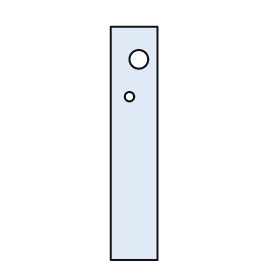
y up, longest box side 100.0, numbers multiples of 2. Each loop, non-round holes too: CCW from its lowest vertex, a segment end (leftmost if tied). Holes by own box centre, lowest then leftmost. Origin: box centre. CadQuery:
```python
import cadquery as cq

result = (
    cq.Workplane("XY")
    .moveTo(-10.0, -50.0)
    .lineTo(10.0, -50.0)
    .lineTo(10.0, 50.0)
    .lineTo(-10.0, 50.0)
    .close()
    .moveTo(-2.0, 20.0)
    .circle(2.0)
    .moveTo(2.0, 36.0)
    .circle(4.0)
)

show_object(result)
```